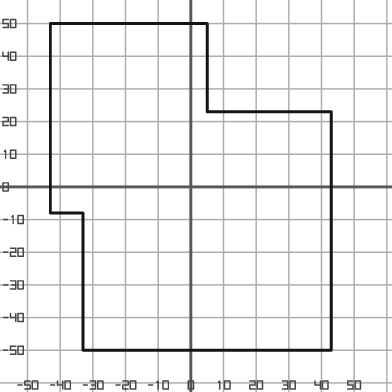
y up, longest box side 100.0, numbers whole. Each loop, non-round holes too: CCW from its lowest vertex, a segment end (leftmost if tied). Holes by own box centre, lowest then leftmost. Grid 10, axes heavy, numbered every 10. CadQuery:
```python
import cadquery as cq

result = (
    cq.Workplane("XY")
    .moveTo(-33.0, -50.0)
    .lineTo(43.0, -50.0)
    .lineTo(43.0, 23.0)
    .lineTo(5.0, 23.0)
    .lineTo(5.0, 50.0)
    .lineTo(-43.0, 50.0)
    .lineTo(-43.0, -8.0)
    .lineTo(-33.0, -8.0)
    .close()
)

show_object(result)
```